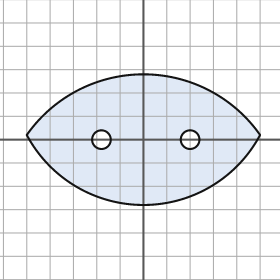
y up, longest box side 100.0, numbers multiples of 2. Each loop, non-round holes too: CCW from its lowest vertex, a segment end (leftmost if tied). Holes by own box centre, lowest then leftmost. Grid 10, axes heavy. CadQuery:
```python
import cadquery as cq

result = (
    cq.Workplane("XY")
    .moveTo(-50.0, 2.0)
    .threePointArc((0.0, -28.0), (50.0, 2.0))
    .threePointArc((0.0, 28.0), (-50.0, 2.0))
    .close()
    .moveTo(-18.0, 0.0)
    .circle(4.0)
    .moveTo(20.0, 0.0)
    .circle(4.0)
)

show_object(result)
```